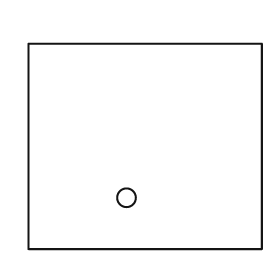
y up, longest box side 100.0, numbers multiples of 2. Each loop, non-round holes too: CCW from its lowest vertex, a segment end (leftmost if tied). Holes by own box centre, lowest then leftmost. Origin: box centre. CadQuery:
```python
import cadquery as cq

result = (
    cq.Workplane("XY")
    .moveTo(-50.0, -44.0)
    .lineTo(50.0, -44.0)
    .lineTo(50.0, 44.0)
    .lineTo(-50.0, 44.0)
    .close()
    .moveTo(-8.0, -22.0)
    .circle(4.0)
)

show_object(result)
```